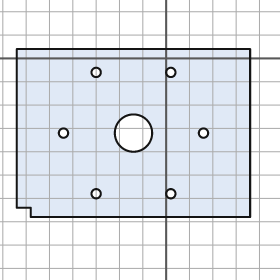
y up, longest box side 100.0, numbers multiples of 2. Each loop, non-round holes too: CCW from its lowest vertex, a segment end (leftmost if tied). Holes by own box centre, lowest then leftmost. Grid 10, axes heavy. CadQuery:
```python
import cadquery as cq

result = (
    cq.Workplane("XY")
    .moveTo(-58.0, -68.0)
    .lineTo(36.0, -68.0)
    .lineTo(36.0, 4.0)
    .lineTo(-64.0, 4.0)
    .lineTo(-64.0, -64.0)
    .lineTo(-58.0, -64.0)
    .close()
    .moveTo(-30.0, -58.0)
    .circle(2.0)
    .moveTo(2.0, -58.0)
    .circle(2.0)
    .moveTo(-44.0, -32.0)
    .circle(2.0)
    .moveTo(-14.0, -32.0)
    .circle(8.0)
    .moveTo(16.0, -32.0)
    .circle(2.0)
    .moveTo(-30.0, -6.0)
    .circle(2.0)
    .moveTo(2.0, -6.0)
    .circle(2.0)
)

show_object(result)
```